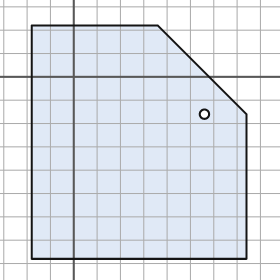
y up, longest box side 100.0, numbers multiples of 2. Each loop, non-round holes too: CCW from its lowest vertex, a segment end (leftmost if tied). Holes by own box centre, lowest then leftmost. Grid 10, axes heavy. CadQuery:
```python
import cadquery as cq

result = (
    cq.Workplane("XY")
    .moveTo(-18.0, -78.0)
    .lineTo(74.0, -78.0)
    .lineTo(74.0, -16.0)
    .lineTo(36.0, 22.0)
    .lineTo(-18.0, 22.0)
    .close()
    .moveTo(56.0, -16.0)
    .circle(2.0)
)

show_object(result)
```